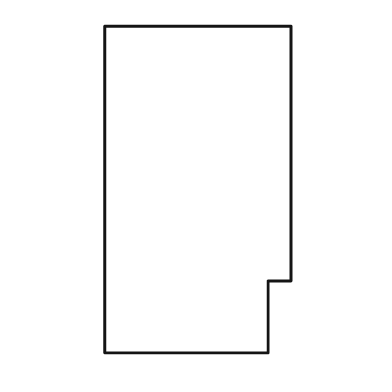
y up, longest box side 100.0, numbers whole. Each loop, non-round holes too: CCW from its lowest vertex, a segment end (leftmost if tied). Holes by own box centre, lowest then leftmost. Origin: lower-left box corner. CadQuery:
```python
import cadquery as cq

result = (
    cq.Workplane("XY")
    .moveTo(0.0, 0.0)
    .lineTo(50.0, 0.0)
    .lineTo(50.0, 22.0)
    .lineTo(57.0, 22.0)
    .lineTo(57.0, 100.0)
    .lineTo(0.0, 100.0)
    .close()
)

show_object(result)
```